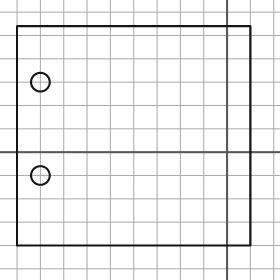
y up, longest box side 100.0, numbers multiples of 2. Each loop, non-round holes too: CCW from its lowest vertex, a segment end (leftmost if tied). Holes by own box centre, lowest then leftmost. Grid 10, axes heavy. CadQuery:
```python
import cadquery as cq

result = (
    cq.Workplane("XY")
    .moveTo(-90.0, -40.0)
    .lineTo(10.0, -40.0)
    .lineTo(10.0, 54.0)
    .lineTo(-90.0, 54.0)
    .close()
    .moveTo(-80.0, -10.0)
    .circle(4.0)
    .moveTo(-80.0, 30.0)
    .circle(4.0)
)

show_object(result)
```